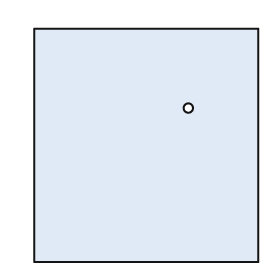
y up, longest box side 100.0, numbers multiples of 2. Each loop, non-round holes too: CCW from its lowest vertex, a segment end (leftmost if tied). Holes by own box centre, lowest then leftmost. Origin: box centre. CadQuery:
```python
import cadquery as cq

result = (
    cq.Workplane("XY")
    .moveTo(-48.0, -50.0)
    .lineTo(48.0, -50.0)
    .lineTo(48.0, 50.0)
    .lineTo(-48.0, 50.0)
    .close()
    .moveTo(18.0, 16.0)
    .circle(2.0)
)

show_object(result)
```